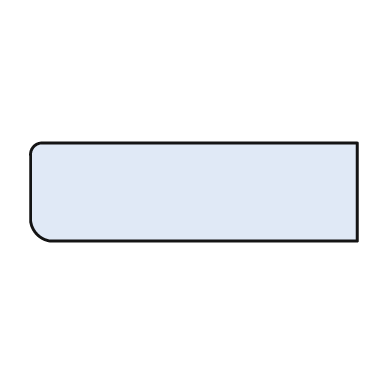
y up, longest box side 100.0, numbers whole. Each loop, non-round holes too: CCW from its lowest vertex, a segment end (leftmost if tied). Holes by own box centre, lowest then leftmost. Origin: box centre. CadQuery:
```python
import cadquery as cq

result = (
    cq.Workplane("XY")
    .moveTo(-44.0, -15.0)
    .lineTo(50.0, -15.0)
    .lineTo(50.0, 15.0)
    .lineTo(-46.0, 15.0)
    .threePointArc((-49.0, 14.0), (-50.0, 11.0))
    .lineTo(-50.0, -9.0)
    .threePointArc((-48.0, -13.0), (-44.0, -15.0))
    .close()
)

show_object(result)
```